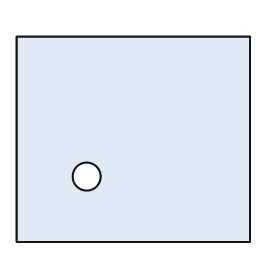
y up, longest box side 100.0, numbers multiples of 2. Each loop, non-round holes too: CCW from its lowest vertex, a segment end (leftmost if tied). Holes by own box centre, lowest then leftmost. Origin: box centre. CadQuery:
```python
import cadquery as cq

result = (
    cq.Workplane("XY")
    .moveTo(-50.0, -44.0)
    .lineTo(50.0, -44.0)
    .lineTo(50.0, 44.0)
    .lineTo(-50.0, 44.0)
    .close()
    .moveTo(-20.0, -16.0)
    .circle(6.0)
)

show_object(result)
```